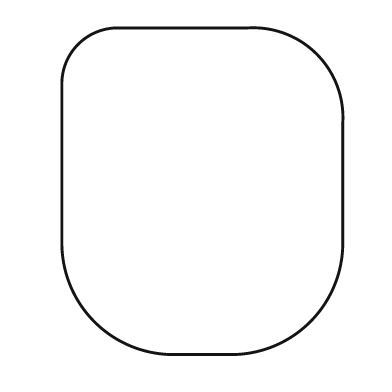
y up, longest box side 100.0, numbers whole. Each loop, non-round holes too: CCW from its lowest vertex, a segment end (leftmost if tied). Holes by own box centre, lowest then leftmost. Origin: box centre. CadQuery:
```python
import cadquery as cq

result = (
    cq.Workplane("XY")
    .moveTo(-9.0, -50.0)
    .lineTo(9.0, -50.0)
    .threePointArc((33.0, -40.0), (43.0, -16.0))
    .lineTo(43.0, 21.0)
    .threePointArc((35.0, 42.0), (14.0, 50.0))
    .lineTo(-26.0, 50.0)
    .threePointArc((-38.0, 45.0), (-43.0, 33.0))
    .lineTo(-43.0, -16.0)
    .threePointArc((-33.0, -40.0), (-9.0, -50.0))
    .close()
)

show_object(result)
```